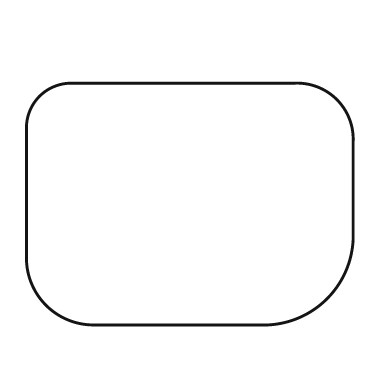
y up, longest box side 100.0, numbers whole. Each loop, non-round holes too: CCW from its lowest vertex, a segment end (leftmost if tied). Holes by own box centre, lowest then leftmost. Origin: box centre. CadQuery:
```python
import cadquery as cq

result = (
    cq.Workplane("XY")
    .moveTo(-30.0, -37.0)
    .lineTo(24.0, -37.0)
    .threePointArc((42.0, -29.0), (50.0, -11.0))
    .lineTo(50.0, 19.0)
    .threePointArc((45.0, 32.0), (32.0, 37.0))
    .lineTo(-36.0, 37.0)
    .threePointArc((-46.0, 33.0), (-50.0, 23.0))
    .lineTo(-50.0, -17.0)
    .threePointArc((-44.0, -31.0), (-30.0, -37.0))
    .close()
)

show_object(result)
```